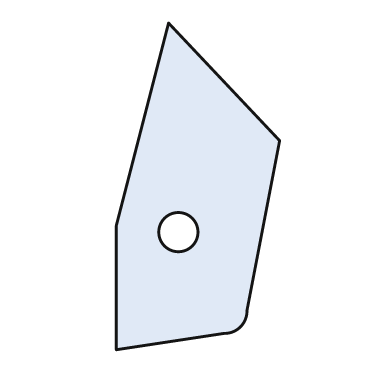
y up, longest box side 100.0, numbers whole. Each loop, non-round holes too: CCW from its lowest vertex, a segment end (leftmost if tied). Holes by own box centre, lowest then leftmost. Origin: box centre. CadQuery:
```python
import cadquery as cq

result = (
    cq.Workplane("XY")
    .moveTo(-25.0, -50.0)
    .lineTo(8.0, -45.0)
    .threePointArc((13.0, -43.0), (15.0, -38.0))
    .lineTo(25.0, 14.0)
    .lineTo(-9.0, 50.0)
    .lineTo(-25.0, -12.0)
    .close()
    .moveTo(-6.0, -14.0)
    .circle(6.0)
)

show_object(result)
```